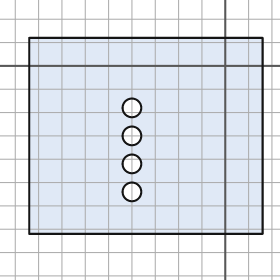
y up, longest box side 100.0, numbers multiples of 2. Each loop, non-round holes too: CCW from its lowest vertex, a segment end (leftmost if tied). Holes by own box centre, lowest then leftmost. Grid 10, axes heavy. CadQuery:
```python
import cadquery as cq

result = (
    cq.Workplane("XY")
    .moveTo(-84.0, -72.0)
    .lineTo(16.0, -72.0)
    .lineTo(16.0, 12.0)
    .lineTo(-84.0, 12.0)
    .close()
    .moveTo(-40.0, -54.0)
    .circle(4.0)
    .moveTo(-40.0, -42.0)
    .circle(4.0)
    .moveTo(-40.0, -30.0)
    .circle(4.0)
    .moveTo(-40.0, -18.0)
    .circle(4.0)
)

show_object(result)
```